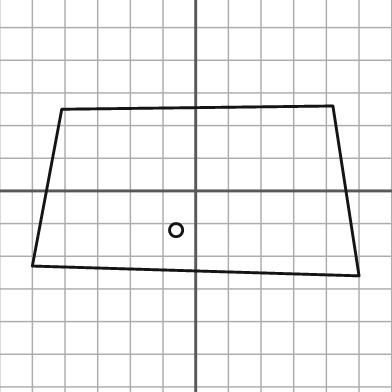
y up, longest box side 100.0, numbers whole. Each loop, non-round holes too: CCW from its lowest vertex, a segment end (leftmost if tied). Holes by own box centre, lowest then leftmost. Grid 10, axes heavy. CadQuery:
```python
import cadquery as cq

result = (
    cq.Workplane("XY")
    .moveTo(50.0, -26.0)
    .lineTo(42.0, 26.0)
    .lineTo(-41.0, 25.0)
    .lineTo(-50.0, -23.0)
    .close()
    .moveTo(-6.0, -12.0)
    .circle(2.0)
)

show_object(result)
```